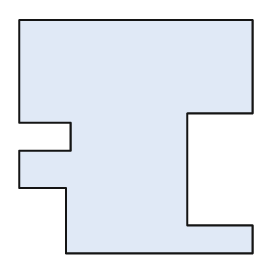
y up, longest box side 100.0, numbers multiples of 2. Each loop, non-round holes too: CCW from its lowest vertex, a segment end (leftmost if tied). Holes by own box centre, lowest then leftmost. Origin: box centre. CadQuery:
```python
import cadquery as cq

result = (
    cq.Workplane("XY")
    .moveTo(-30.0, -50.0)
    .lineTo(50.0, -50.0)
    .lineTo(50.0, -38.0)
    .lineTo(22.0, -38.0)
    .lineTo(22.0, 10.0)
    .lineTo(50.0, 10.0)
    .lineTo(50.0, 50.0)
    .lineTo(-50.0, 50.0)
    .lineTo(-50.0, 6.0)
    .lineTo(-28.0, 6.0)
    .lineTo(-28.0, -6.0)
    .lineTo(-50.0, -6.0)
    .lineTo(-50.0, -22.0)
    .lineTo(-30.0, -22.0)
    .close()
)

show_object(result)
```